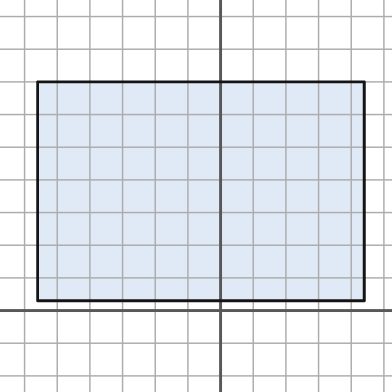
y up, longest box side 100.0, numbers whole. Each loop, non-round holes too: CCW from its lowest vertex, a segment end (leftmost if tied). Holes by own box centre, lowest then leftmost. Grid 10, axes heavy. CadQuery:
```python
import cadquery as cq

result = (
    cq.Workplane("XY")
    .moveTo(-56.0, 3.0)
    .lineTo(44.0, 3.0)
    .lineTo(44.0, 70.0)
    .lineTo(-56.0, 70.0)
    .close()
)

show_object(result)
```